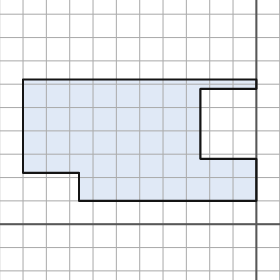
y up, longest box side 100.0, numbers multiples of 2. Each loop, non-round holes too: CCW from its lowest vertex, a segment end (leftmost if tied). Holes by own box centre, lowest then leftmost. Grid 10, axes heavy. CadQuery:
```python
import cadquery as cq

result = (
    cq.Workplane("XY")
    .moveTo(-76.0, 10.0)
    .lineTo(0.0, 10.0)
    .lineTo(0.0, 28.0)
    .lineTo(-24.0, 28.0)
    .lineTo(-24.0, 58.0)
    .lineTo(0.0, 58.0)
    .lineTo(0.0, 62.0)
    .lineTo(-100.0, 62.0)
    .lineTo(-100.0, 22.0)
    .lineTo(-76.0, 22.0)
    .close()
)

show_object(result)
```